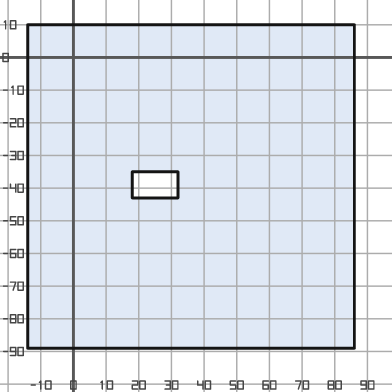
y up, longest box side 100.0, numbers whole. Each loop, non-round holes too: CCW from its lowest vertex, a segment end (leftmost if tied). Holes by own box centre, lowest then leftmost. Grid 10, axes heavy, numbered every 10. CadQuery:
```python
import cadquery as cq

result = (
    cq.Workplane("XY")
    .moveTo(-14.0, -89.0)
    .lineTo(86.0, -89.0)
    .lineTo(86.0, 10.0)
    .lineTo(-14.0, 10.0)
    .close()
    .moveTo(18.0, -43.0)
    .lineTo(32.0, -43.0)
    .lineTo(32.0, -35.0)
    .lineTo(18.0, -35.0)
    .close()
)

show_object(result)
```